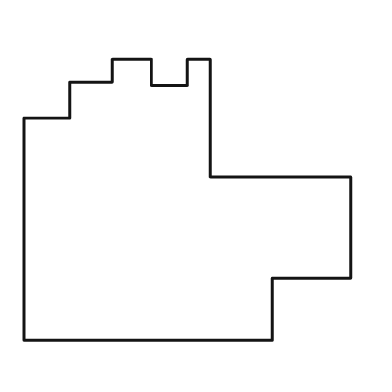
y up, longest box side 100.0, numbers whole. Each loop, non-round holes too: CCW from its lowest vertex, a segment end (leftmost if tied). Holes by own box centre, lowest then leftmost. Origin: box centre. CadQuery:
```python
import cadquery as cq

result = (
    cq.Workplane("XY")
    .moveTo(-50.0, -43.0)
    .lineTo(26.0, -43.0)
    .lineTo(26.0, -24.0)
    .lineTo(50.0, -24.0)
    .lineTo(50.0, 7.0)
    .lineTo(7.0, 7.0)
    .lineTo(7.0, 43.0)
    .lineTo(0.0, 43.0)
    .lineTo(0.0, 35.0)
    .lineTo(-11.0, 35.0)
    .lineTo(-11.0, 43.0)
    .lineTo(-23.0, 43.0)
    .lineTo(-23.0, 36.0)
    .lineTo(-36.0, 36.0)
    .lineTo(-36.0, 25.0)
    .lineTo(-50.0, 25.0)
    .close()
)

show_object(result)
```